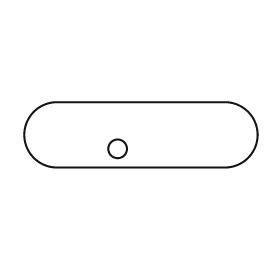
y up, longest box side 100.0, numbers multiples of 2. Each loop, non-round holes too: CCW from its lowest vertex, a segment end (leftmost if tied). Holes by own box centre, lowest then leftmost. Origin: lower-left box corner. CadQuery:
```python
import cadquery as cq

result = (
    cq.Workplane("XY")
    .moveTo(14.0, 0.0)
    .lineTo(86.0, 0.0)
    .threePointArc((100.0, 14.0), (86.0, 28.0))
    .lineTo(14.0, 28.0)
    .threePointArc((0.0, 14.0), (14.0, 0.0))
    .close()
    .moveTo(40.0, 8.0)
    .circle(4.0)
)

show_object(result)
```